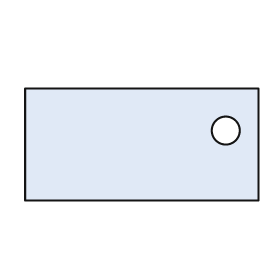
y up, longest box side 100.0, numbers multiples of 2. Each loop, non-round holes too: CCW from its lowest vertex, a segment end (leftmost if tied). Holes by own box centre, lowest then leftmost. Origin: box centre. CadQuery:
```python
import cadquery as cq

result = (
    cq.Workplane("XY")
    .moveTo(-50.0, -24.0)
    .lineTo(50.0, -24.0)
    .lineTo(50.0, 24.0)
    .lineTo(-50.0, 24.0)
    .close()
    .moveTo(36.0, 6.0)
    .circle(6.0)
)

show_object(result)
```